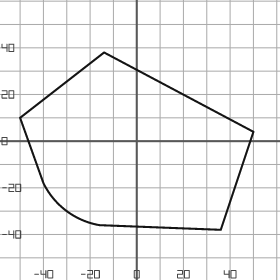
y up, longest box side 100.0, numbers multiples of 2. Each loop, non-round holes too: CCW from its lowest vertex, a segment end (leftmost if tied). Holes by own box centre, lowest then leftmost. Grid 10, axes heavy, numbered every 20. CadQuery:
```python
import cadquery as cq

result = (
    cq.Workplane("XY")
    .moveTo(36.0, -38.0)
    .lineTo(50.0, 4.0)
    .lineTo(-14.0, 38.0)
    .lineTo(-50.0, 10.0)
    .lineTo(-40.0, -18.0)
    .threePointArc((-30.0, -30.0), (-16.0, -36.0))
    .close()
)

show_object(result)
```